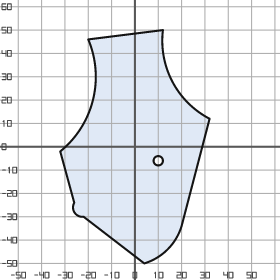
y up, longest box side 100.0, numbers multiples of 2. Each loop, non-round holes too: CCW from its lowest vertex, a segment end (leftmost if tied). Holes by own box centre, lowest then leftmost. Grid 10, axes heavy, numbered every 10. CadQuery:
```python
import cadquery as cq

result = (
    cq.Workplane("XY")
    .moveTo(4.0, -50.0)
    .threePointArc((14.0, -44.0), (20.0, -34.0))
    .lineTo(32.0, 12.0)
    .threePointArc((16.0, 28.0), (12.0, 50.0))
    .lineTo(-20.0, 46.0)
    .threePointArc((-18.0, 20.0), (-32.0, -2.0))
    .lineTo(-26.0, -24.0)
    .threePointArc((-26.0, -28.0), (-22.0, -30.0))
    .close()
    .moveTo(10.0, -6.0)
    .circle(2.0)
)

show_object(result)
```